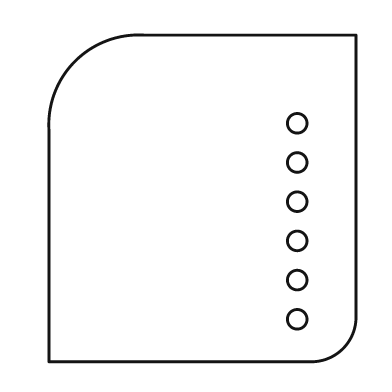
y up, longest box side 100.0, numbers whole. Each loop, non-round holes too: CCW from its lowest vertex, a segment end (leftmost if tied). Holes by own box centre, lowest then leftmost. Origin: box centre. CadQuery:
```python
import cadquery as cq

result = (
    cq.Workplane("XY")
    .moveTo(-47.0, -50.0)
    .lineTo(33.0, -50.0)
    .threePointArc((43.0, -46.0), (47.0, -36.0))
    .lineTo(47.0, 50.0)
    .lineTo(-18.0, 50.0)
    .threePointArc((-39.0, 42.0), (-47.0, 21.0))
    .close()
    .moveTo(29.0, -37.0)
    .circle(3.0)
    .moveTo(29.0, -25.0)
    .circle(3.0)
    .moveTo(29.0, -13.0)
    .circle(3.0)
    .moveTo(29.0, -1.0)
    .circle(3.0)
    .moveTo(29.0, 11.0)
    .circle(3.0)
    .moveTo(29.0, 23.0)
    .circle(3.0)
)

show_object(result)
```